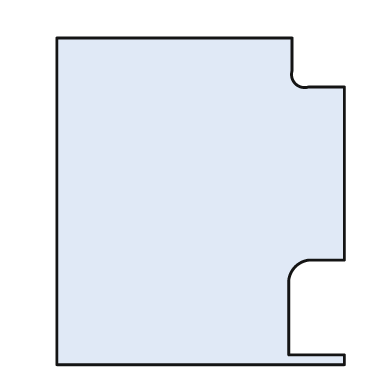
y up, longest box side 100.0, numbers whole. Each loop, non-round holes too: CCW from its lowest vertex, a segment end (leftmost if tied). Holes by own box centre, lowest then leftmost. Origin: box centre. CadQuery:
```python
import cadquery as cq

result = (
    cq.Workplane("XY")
    .moveTo(-44.0, -50.0)
    .lineTo(44.0, -50.0)
    .lineTo(44.0, -47.0)
    .lineTo(27.0, -47.0)
    .lineTo(27.0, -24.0)
    .threePointArc((29.0, -20.0), (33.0, -18.0))
    .lineTo(44.0, -18.0)
    .lineTo(44.0, 35.0)
    .lineTo(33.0, 35.0)
    .threePointArc((29.0, 36.0), (28.0, 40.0))
    .lineTo(28.0, 50.0)
    .lineTo(-44.0, 50.0)
    .close()
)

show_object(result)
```